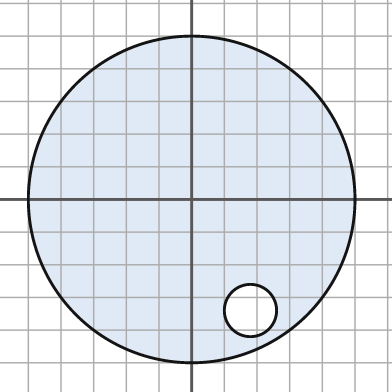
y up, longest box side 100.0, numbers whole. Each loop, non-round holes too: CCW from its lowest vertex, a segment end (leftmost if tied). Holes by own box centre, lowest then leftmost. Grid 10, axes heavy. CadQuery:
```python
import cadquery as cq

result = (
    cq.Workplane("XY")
    .moveTo(0.0, 0.0)
    .circle(50.0)
    .moveTo(18.0, -34.0)
    .circle(8.0)
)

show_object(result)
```